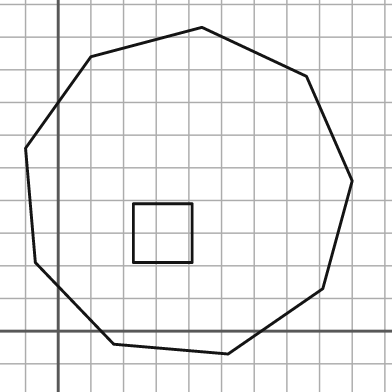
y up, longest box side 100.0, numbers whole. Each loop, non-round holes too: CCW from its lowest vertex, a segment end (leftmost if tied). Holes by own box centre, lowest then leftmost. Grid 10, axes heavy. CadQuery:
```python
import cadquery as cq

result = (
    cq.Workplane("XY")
    .moveTo(52.0, -7.0)
    .lineTo(81.0, 13.0)
    .lineTo(90.0, 46.0)
    .lineTo(76.0, 78.0)
    .lineTo(44.0, 93.0)
    .lineTo(10.0, 84.0)
    .lineTo(-10.0, 56.0)
    .lineTo(-7.0, 21.0)
    .lineTo(17.0, -4.0)
    .close()
    .moveTo(23.0, 21.0)
    .lineTo(41.0, 21.0)
    .lineTo(41.0, 39.0)
    .lineTo(23.0, 39.0)
    .close()
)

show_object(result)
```